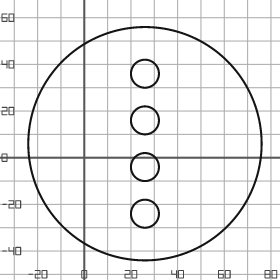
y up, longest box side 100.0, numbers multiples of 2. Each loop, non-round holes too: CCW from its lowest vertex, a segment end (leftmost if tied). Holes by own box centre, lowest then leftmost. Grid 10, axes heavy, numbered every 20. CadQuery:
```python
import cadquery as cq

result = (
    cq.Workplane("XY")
    .moveTo(26.0, 6.0)
    .circle(50.0)
    .moveTo(26.0, -24.0)
    .circle(6.0)
    .moveTo(26.0, -4.0)
    .circle(6.0)
    .moveTo(26.0, 16.0)
    .circle(6.0)
    .moveTo(26.0, 36.0)
    .circle(6.0)
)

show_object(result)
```